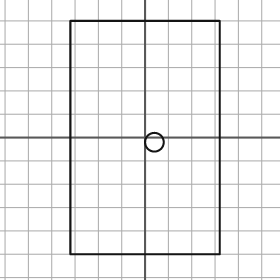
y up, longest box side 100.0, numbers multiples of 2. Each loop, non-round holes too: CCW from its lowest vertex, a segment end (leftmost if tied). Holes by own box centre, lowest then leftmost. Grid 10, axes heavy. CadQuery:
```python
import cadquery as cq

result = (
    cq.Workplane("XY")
    .moveTo(-32.0, -50.0)
    .lineTo(32.0, -50.0)
    .lineTo(32.0, 50.0)
    .lineTo(-32.0, 50.0)
    .close()
    .moveTo(4.0, -2.0)
    .circle(4.0)
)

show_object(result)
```